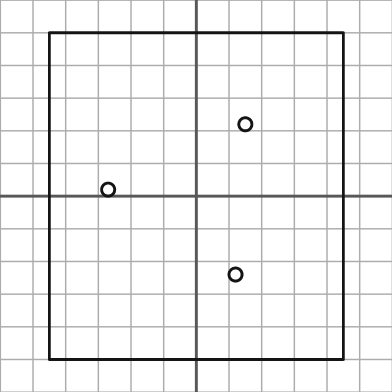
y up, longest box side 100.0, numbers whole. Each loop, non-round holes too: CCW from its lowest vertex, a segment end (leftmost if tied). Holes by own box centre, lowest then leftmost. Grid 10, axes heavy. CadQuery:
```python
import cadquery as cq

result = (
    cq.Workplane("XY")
    .moveTo(-45.0, -50.0)
    .lineTo(45.0, -50.0)
    .lineTo(45.0, 50.0)
    .lineTo(-45.0, 50.0)
    .close()
    .moveTo(12.0, -24.0)
    .circle(2.0)
    .moveTo(-27.0, 2.0)
    .circle(2.0)
    .moveTo(15.0, 22.0)
    .circle(2.0)
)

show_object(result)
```